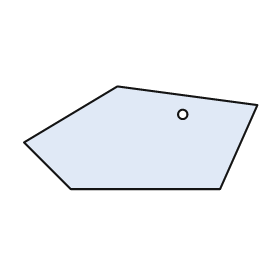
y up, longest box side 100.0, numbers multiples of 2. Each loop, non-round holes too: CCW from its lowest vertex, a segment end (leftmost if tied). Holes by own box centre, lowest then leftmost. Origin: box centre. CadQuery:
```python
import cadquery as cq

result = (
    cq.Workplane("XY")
    .moveTo(-30.0, -22.0)
    .lineTo(34.0, -22.0)
    .lineTo(50.0, 14.0)
    .lineTo(-10.0, 22.0)
    .lineTo(-50.0, -2.0)
    .close()
    .moveTo(18.0, 10.0)
    .circle(2.0)
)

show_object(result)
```